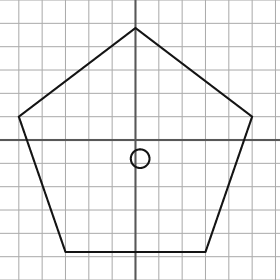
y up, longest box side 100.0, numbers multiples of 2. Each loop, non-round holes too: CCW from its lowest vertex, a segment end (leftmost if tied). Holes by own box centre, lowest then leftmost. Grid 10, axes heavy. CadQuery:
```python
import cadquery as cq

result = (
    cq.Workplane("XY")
    .moveTo(-30.0, -48.0)
    .lineTo(30.0, -48.0)
    .lineTo(50.0, 10.0)
    .lineTo(0.0, 48.0)
    .lineTo(-50.0, 10.0)
    .close()
    .moveTo(2.0, -8.0)
    .circle(4.0)
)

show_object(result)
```